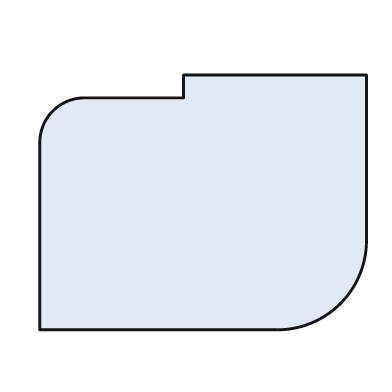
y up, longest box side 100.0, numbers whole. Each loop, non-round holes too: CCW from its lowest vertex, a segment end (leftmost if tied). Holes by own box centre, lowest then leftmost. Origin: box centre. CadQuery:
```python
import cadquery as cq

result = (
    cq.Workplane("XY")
    .moveTo(-50.0, -39.0)
    .lineTo(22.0, -39.0)
    .threePointArc((42.0, -31.0), (50.0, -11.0))
    .lineTo(50.0, 39.0)
    .lineTo(-6.0, 39.0)
    .lineTo(-6.0, 32.0)
    .lineTo(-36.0, 32.0)
    .threePointArc((-46.0, 28.0), (-50.0, 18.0))
    .close()
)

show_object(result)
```